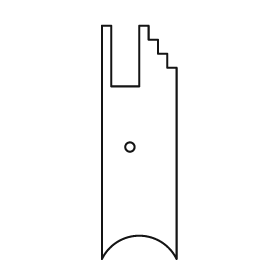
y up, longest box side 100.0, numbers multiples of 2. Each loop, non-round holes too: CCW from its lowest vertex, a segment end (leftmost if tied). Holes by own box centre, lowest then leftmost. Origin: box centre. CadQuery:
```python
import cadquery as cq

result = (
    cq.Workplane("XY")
    .moveTo(-16.0, -50.0)
    .threePointArc((0.0, -40.0), (16.0, -50.0))
    .lineTo(16.0, 32.0)
    .lineTo(12.0, 32.0)
    .lineTo(12.0, 38.0)
    .lineTo(8.0, 38.0)
    .lineTo(8.0, 44.0)
    .lineTo(4.0, 44.0)
    .lineTo(4.0, 50.0)
    .lineTo(0.0, 50.0)
    .lineTo(0.0, 24.0)
    .lineTo(-12.0, 24.0)
    .lineTo(-12.0, 50.0)
    .lineTo(-16.0, 50.0)
    .close()
    .moveTo(-4.0, -2.0)
    .circle(2.0)
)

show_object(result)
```